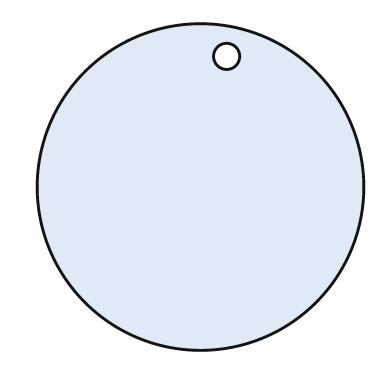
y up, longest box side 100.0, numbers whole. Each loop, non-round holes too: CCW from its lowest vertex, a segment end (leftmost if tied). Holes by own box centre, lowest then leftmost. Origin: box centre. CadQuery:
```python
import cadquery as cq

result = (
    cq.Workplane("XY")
    .moveTo(0.0, 0.0)
    .circle(50.0)
    .moveTo(8.0, 40.0)
    .circle(4.0)
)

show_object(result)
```